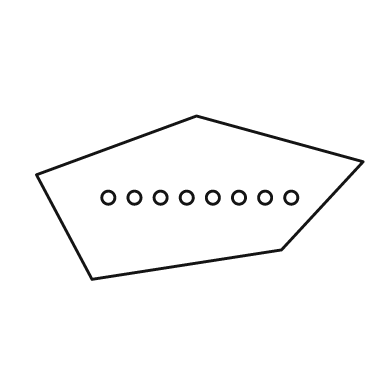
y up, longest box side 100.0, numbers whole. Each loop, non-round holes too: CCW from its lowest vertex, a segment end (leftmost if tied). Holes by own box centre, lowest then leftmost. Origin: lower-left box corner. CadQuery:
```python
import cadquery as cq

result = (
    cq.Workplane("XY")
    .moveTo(17.0, 0.0)
    .lineTo(75.0, 9.0)
    .lineTo(100.0, 36.0)
    .lineTo(49.0, 50.0)
    .lineTo(0.0, 32.0)
    .close()
    .moveTo(22.0, 25.0)
    .circle(2.0)
    .moveTo(30.0, 25.0)
    .circle(2.0)
    .moveTo(38.0, 25.0)
    .circle(2.0)
    .moveTo(46.0, 25.0)
    .circle(2.0)
    .moveTo(54.0, 25.0)
    .circle(2.0)
    .moveTo(62.0, 25.0)
    .circle(2.0)
    .moveTo(70.0, 25.0)
    .circle(2.0)
    .moveTo(78.0, 25.0)
    .circle(2.0)
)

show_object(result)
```